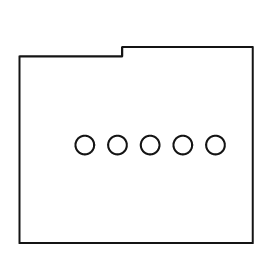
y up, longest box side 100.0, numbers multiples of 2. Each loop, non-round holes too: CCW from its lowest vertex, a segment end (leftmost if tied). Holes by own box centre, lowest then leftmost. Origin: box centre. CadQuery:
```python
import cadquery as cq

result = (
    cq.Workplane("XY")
    .moveTo(-50.0, -42.0)
    .lineTo(50.0, -42.0)
    .lineTo(50.0, 42.0)
    .lineTo(-6.0, 42.0)
    .lineTo(-6.0, 38.0)
    .lineTo(-50.0, 38.0)
    .close()
    .moveTo(-22.0, 0.0)
    .circle(4.0)
    .moveTo(-8.0, 0.0)
    .circle(4.0)
    .moveTo(6.0, 0.0)
    .circle(4.0)
    .moveTo(20.0, 0.0)
    .circle(4.0)
    .moveTo(34.0, 0.0)
    .circle(4.0)
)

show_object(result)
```